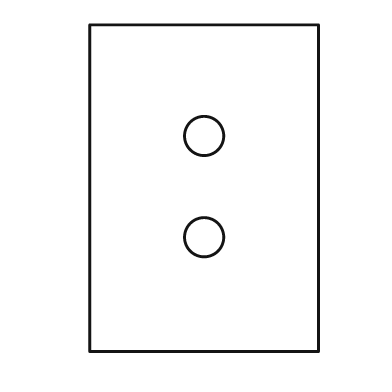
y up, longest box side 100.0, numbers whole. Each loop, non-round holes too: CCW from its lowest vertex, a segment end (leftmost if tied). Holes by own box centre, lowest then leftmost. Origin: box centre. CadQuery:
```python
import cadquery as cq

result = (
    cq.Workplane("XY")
    .moveTo(-35.0, -50.0)
    .lineTo(35.0, -50.0)
    .lineTo(35.0, 50.0)
    .lineTo(-35.0, 50.0)
    .close()
    .moveTo(0.0, -15.0)
    .circle(6.0)
    .moveTo(0.0, 16.0)
    .circle(6.0)
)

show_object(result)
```